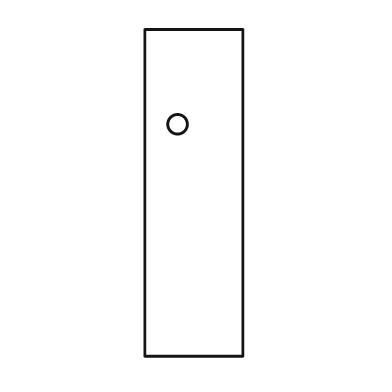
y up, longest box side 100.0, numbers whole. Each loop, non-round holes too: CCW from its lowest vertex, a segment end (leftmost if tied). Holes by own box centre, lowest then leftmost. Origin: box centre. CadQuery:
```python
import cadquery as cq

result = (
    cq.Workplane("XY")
    .moveTo(-15.0, -50.0)
    .lineTo(15.0, -50.0)
    .lineTo(15.0, 50.0)
    .lineTo(-15.0, 50.0)
    .close()
    .moveTo(-5.0, 21.0)
    .circle(3.0)
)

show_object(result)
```